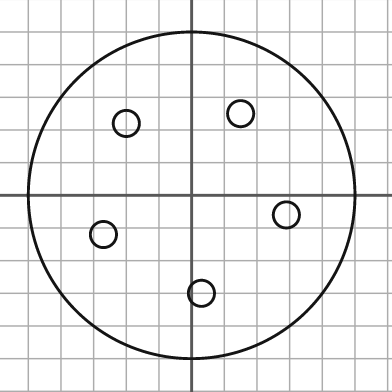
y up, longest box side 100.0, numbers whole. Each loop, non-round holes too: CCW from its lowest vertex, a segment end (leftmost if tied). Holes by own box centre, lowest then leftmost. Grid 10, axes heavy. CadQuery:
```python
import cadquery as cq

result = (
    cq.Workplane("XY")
    .moveTo(0.0, 0.0)
    .circle(50.0)
    .moveTo(3.0, -30.0)
    .circle(4.0)
    .moveTo(-27.0, -12.0)
    .circle(4.0)
    .moveTo(29.0, -6.0)
    .circle(4.0)
    .moveTo(-20.0, 22.0)
    .circle(4.0)
    .moveTo(15.0, 25.0)
    .circle(4.0)
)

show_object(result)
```